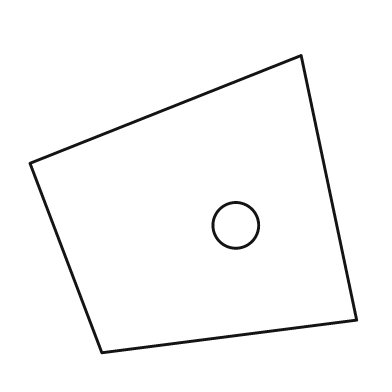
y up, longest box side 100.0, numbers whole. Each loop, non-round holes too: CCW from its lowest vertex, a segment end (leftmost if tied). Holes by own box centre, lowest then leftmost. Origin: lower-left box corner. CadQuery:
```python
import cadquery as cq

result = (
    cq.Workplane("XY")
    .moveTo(22.0, 0.0)
    .lineTo(100.0, 10.0)
    .lineTo(83.0, 91.0)
    .lineTo(0.0, 58.0)
    .close()
    .moveTo(63.0, 39.0)
    .circle(7.0)
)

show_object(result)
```